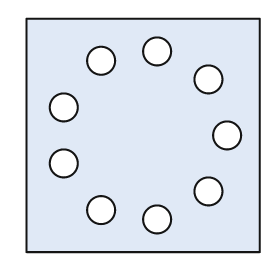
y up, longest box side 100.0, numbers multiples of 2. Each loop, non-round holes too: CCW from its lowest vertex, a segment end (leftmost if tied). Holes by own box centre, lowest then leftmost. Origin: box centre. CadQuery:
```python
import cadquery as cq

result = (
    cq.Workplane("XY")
    .moveTo(-50.0, -50.0)
    .lineTo(50.0, -50.0)
    .lineTo(50.0, 50.0)
    .lineTo(-50.0, 50.0)
    .close()
    .moveTo(6.0, -36.0)
    .circle(6.0)
    .moveTo(-18.0, -32.0)
    .circle(6.0)
    .moveTo(28.0, -24.0)
    .circle(6.0)
    .moveTo(-34.0, -12.0)
    .circle(6.0)
    .moveTo(36.0, 0.0)
    .circle(6.0)
    .moveTo(-34.0, 12.0)
    .circle(6.0)
    .moveTo(28.0, 24.0)
    .circle(6.0)
    .moveTo(-18.0, 32.0)
    .circle(6.0)
    .moveTo(6.0, 36.0)
    .circle(6.0)
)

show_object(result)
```